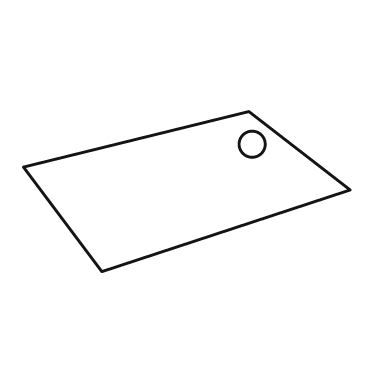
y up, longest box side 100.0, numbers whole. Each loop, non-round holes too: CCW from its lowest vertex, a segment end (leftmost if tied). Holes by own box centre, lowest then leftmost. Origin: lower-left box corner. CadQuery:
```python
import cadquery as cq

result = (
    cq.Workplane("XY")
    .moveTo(24.0, 0.0)
    .lineTo(100.0, 25.0)
    .lineTo(69.0, 49.0)
    .lineTo(0.0, 32.0)
    .close()
    .moveTo(70.0, 39.0)
    .circle(4.0)
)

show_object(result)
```